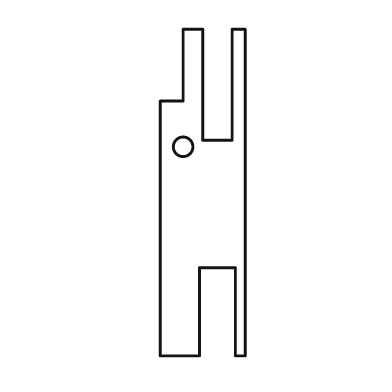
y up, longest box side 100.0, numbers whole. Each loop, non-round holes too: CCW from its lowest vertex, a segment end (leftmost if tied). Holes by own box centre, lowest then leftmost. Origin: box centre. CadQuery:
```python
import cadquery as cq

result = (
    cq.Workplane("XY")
    .moveTo(-13.0, -50.0)
    .lineTo(-1.0, -50.0)
    .lineTo(-1.0, -23.0)
    .lineTo(10.0, -23.0)
    .lineTo(10.0, -50.0)
    .lineTo(13.0, -50.0)
    .lineTo(13.0, 50.0)
    .lineTo(9.0, 50.0)
    .lineTo(9.0, 16.0)
    .lineTo(0.0, 16.0)
    .lineTo(0.0, 50.0)
    .lineTo(-6.0, 50.0)
    .lineTo(-6.0, 28.0)
    .lineTo(-13.0, 28.0)
    .close()
    .moveTo(-6.0, 14.0)
    .circle(3.0)
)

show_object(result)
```